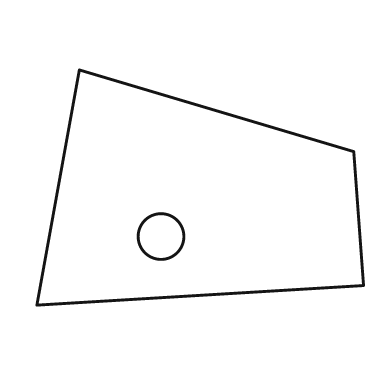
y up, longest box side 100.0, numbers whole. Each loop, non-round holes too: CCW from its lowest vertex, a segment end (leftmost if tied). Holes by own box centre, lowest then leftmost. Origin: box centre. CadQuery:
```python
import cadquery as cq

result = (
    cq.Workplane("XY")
    .moveTo(-50.0, -36.0)
    .lineTo(50.0, -30.0)
    .lineTo(47.0, 11.0)
    .lineTo(-37.0, 36.0)
    .close()
    .moveTo(-12.0, -15.0)
    .circle(7.0)
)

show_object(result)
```